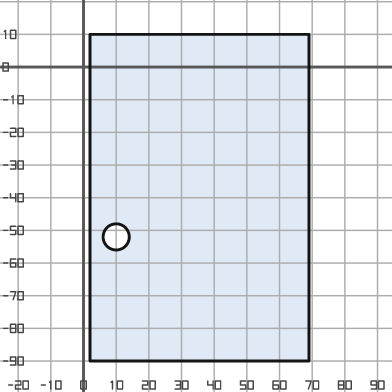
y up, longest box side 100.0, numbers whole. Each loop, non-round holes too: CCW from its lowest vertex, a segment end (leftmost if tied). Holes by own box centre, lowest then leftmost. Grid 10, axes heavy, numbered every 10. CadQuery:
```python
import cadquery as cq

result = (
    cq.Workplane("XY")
    .moveTo(2.0, -90.0)
    .lineTo(69.0, -90.0)
    .lineTo(69.0, 10.0)
    .lineTo(2.0, 10.0)
    .close()
    .moveTo(10.0, -52.0)
    .circle(4.0)
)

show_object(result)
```